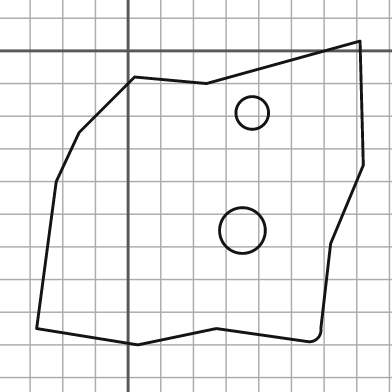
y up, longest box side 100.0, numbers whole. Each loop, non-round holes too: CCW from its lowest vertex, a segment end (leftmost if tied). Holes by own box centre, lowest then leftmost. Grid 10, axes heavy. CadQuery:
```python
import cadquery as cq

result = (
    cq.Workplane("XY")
    .moveTo(3.0, -90.0)
    .lineTo(27.0, -85.0)
    .lineTo(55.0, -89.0)
    .threePointArc((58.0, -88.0), (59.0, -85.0))
    .lineTo(62.0, -59.0)
    .lineTo(72.0, -35.0)
    .lineTo(71.0, 3.0)
    .lineTo(24.0, -10.0)
    .lineTo(2.0, -8.0)
    .lineTo(-15.0, -25.0)
    .lineTo(-22.0, -40.0)
    .lineTo(-28.0, -85.0)
    .close()
    .moveTo(35.0, -55.0)
    .circle(7.0)
    .moveTo(38.0, -19.0)
    .circle(5.0)
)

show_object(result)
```